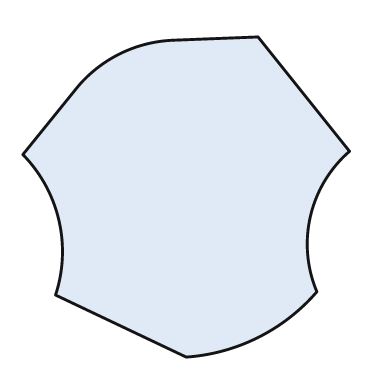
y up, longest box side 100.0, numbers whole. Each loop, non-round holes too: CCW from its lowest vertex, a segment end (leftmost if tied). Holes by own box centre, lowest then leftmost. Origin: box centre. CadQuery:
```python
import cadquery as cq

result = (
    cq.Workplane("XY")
    .moveTo(0.0, -49.0)
    .threePointArc((22.0, -43.0), (40.0, -29.0))
    .threePointArc((38.0, -6.0), (50.0, 14.0))
    .lineTo(22.0, 49.0)
    .lineTo(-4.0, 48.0)
    .threePointArc((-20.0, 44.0), (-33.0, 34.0))
    .lineTo(-50.0, 13.0)
    .threePointArc((-39.0, -7.0), (-40.0, -30.0))
    .close()
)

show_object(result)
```